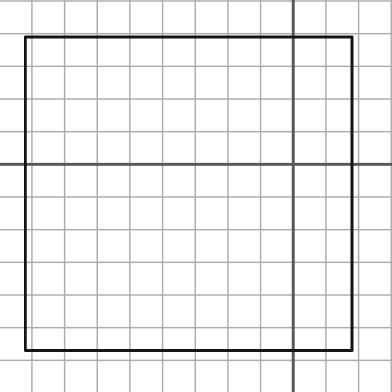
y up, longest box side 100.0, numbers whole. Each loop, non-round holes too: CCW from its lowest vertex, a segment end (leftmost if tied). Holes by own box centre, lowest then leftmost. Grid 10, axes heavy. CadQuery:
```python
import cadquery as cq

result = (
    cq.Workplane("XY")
    .moveTo(-82.0, -57.0)
    .lineTo(18.0, -57.0)
    .lineTo(18.0, 39.0)
    .lineTo(-82.0, 39.0)
    .close()
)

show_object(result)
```